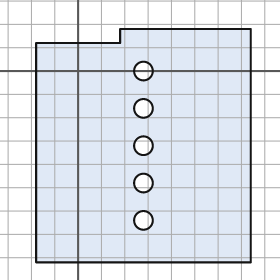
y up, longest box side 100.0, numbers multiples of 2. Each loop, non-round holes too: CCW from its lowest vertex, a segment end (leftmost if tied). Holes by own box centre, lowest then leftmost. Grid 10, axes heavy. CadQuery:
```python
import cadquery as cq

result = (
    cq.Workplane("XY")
    .moveTo(-18.0, -82.0)
    .lineTo(74.0, -82.0)
    .lineTo(74.0, 18.0)
    .lineTo(18.0, 18.0)
    .lineTo(18.0, 12.0)
    .lineTo(-18.0, 12.0)
    .close()
    .moveTo(28.0, -64.0)
    .circle(4.0)
    .moveTo(28.0, -48.0)
    .circle(4.0)
    .moveTo(28.0, -32.0)
    .circle(4.0)
    .moveTo(28.0, -16.0)
    .circle(4.0)
    .moveTo(28.0, 0.0)
    .circle(4.0)
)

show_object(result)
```